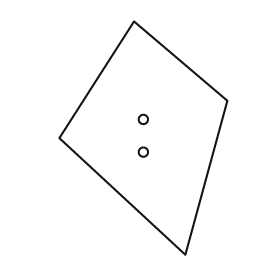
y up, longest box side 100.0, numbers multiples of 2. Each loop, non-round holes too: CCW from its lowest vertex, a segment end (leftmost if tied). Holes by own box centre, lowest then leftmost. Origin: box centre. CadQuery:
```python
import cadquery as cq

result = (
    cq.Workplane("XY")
    .moveTo(18.0, -50.0)
    .lineTo(36.0, 16.0)
    .lineTo(-4.0, 50.0)
    .lineTo(-36.0, 0.0)
    .close()
    .moveTo(0.0, -6.0)
    .circle(2.0)
    .moveTo(0.0, 8.0)
    .circle(2.0)
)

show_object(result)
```